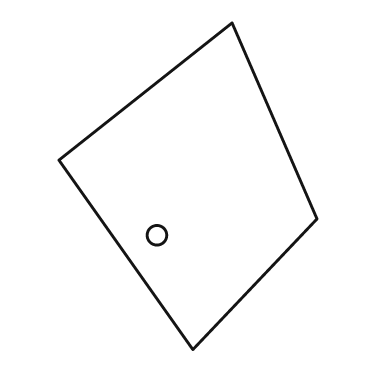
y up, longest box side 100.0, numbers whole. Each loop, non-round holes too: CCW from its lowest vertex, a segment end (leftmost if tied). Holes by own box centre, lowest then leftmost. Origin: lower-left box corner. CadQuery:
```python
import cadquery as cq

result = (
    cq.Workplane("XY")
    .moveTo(41.0, 0.0)
    .lineTo(79.0, 40.0)
    .lineTo(53.0, 100.0)
    .lineTo(0.0, 58.0)
    .close()
    .moveTo(30.0, 35.0)
    .circle(3.0)
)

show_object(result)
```